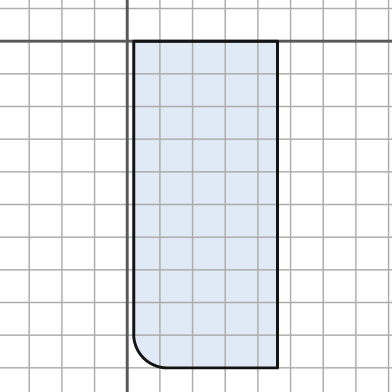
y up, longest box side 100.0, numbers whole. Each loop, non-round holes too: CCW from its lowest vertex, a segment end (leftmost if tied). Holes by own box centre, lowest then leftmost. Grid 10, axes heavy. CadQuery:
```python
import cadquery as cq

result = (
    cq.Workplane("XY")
    .moveTo(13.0, -100.0)
    .lineTo(46.0, -100.0)
    .lineTo(46.0, 0.0)
    .lineTo(2.0, 0.0)
    .lineTo(2.0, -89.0)
    .threePointArc((5.0, -97.0), (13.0, -100.0))
    .close()
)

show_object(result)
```